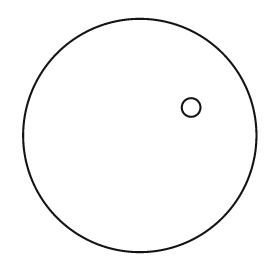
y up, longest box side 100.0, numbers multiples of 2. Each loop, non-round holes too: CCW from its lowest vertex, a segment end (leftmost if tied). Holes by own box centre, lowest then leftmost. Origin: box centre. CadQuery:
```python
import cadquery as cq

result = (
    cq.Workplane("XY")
    .moveTo(0.0, 0.0)
    .circle(50.0)
    .moveTo(22.0, 12.0)
    .circle(4.0)
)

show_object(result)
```